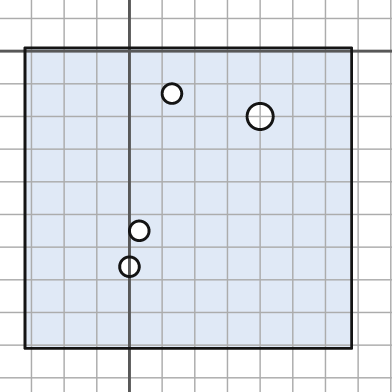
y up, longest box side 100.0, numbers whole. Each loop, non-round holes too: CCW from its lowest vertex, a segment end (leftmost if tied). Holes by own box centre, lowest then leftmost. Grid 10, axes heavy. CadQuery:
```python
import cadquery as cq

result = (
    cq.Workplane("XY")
    .moveTo(-32.0, -91.0)
    .lineTo(68.0, -91.0)
    .lineTo(68.0, 1.0)
    .lineTo(-32.0, 1.0)
    .close()
    .moveTo(0.0, -66.0)
    .circle(3.0)
    .moveTo(3.0, -55.0)
    .circle(3.0)
    .moveTo(40.0, -20.0)
    .circle(4.0)
    .moveTo(13.0, -13.0)
    .circle(3.0)
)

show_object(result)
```